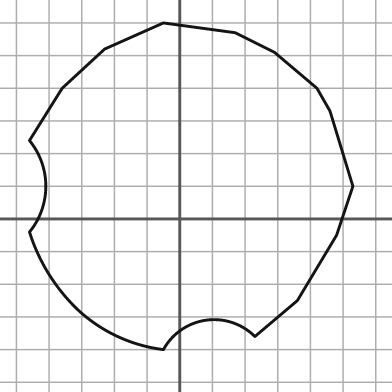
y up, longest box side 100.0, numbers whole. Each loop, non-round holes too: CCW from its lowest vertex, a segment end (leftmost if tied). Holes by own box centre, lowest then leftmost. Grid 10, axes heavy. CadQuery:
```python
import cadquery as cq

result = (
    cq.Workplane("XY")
    .moveTo(-5.0, -40.0)
    .threePointArc((8.0, -31.0), (23.0, -36.0))
    .lineTo(36.0, -25.0)
    .lineTo(48.0, -5.0)
    .lineTo(53.0, 10.0)
    .lineTo(46.0, 33.0)
    .lineTo(42.0, 40.0)
    .lineTo(29.0, 51.0)
    .lineTo(17.0, 57.0)
    .lineTo(-5.0, 60.0)
    .lineTo(-23.0, 52.0)
    .lineTo(-36.0, 40.0)
    .lineTo(-46.0, 24.0)
    .threePointArc((-41.0, 10.0), (-46.0, -4.0))
    .threePointArc((-40.0, -17.0), (-31.0, -28.0))
    .threePointArc((-19.0, -36.0), (-5.0, -40.0))
    .close()
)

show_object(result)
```